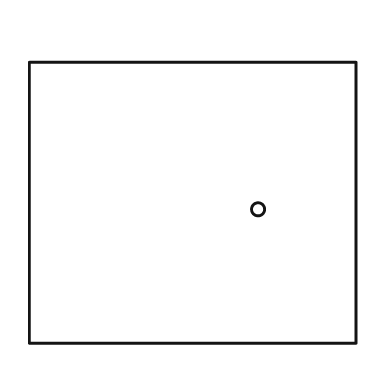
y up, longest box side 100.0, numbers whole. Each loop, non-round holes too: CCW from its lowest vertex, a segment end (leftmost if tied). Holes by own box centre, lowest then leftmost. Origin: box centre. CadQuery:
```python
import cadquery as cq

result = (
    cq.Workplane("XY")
    .moveTo(-50.0, -43.0)
    .lineTo(50.0, -43.0)
    .lineTo(50.0, 43.0)
    .lineTo(-50.0, 43.0)
    .close()
    .moveTo(20.0, -2.0)
    .circle(2.0)
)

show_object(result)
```